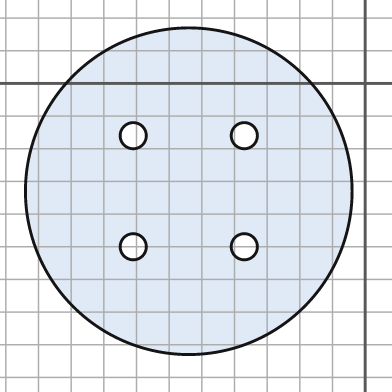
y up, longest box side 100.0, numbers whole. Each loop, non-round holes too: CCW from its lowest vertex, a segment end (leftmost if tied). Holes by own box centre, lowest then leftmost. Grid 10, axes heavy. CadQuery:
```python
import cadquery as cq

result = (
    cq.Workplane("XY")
    .moveTo(-54.0, -33.0)
    .circle(50.0)
    .moveTo(-71.0, -50.0)
    .circle(4.0)
    .moveTo(-37.0, -50.0)
    .circle(4.0)
    .moveTo(-71.0, -16.0)
    .circle(4.0)
    .moveTo(-37.0, -16.0)
    .circle(4.0)
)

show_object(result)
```